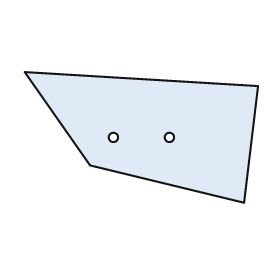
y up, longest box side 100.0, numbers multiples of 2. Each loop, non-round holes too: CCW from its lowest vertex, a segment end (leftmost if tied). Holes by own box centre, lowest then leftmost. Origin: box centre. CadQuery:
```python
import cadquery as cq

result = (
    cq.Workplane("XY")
    .moveTo(44.0, -28.0)
    .lineTo(50.0, 22.0)
    .lineTo(-50.0, 28.0)
    .lineTo(-22.0, -12.0)
    .close()
    .moveTo(-12.0, 0.0)
    .circle(2.0)
    .moveTo(12.0, 0.0)
    .circle(2.0)
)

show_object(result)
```